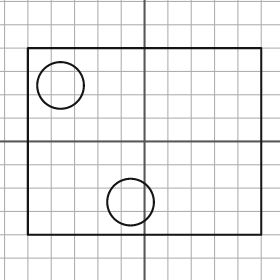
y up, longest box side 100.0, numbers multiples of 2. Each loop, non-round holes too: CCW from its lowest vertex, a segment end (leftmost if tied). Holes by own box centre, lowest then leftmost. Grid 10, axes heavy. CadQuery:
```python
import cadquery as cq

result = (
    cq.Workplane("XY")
    .moveTo(-50.0, -40.0)
    .lineTo(50.0, -40.0)
    .lineTo(50.0, 40.0)
    .lineTo(-50.0, 40.0)
    .close()
    .moveTo(-6.0, -26.0)
    .circle(10.0)
    .moveTo(-36.0, 24.0)
    .circle(10.0)
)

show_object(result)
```